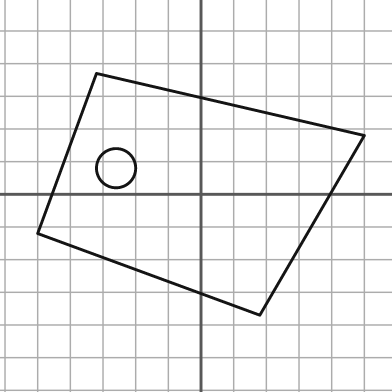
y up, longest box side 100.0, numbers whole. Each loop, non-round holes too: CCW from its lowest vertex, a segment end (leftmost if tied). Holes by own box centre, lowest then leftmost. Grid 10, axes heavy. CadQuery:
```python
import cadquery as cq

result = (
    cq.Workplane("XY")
    .moveTo(18.0, -37.0)
    .lineTo(50.0, 18.0)
    .lineTo(-32.0, 37.0)
    .lineTo(-50.0, -12.0)
    .close()
    .moveTo(-26.0, 8.0)
    .circle(6.0)
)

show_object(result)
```